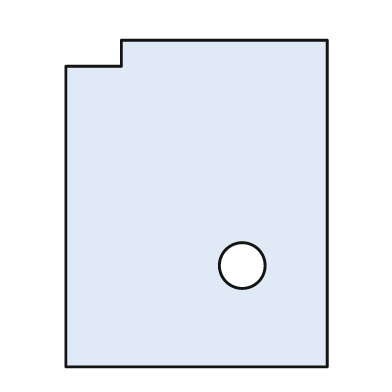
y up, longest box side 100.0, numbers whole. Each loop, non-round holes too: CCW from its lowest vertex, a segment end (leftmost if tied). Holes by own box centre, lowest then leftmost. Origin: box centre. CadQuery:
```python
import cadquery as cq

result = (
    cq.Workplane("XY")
    .moveTo(-40.0, -50.0)
    .lineTo(40.0, -50.0)
    .lineTo(40.0, 50.0)
    .lineTo(-23.0, 50.0)
    .lineTo(-23.0, 42.0)
    .lineTo(-40.0, 42.0)
    .close()
    .moveTo(14.0, -19.0)
    .circle(7.0)
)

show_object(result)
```